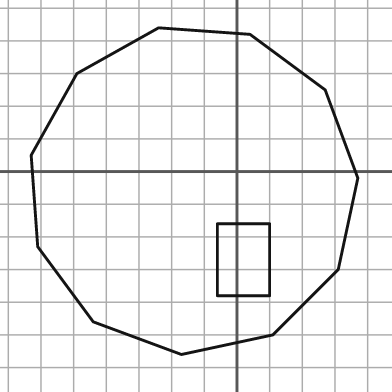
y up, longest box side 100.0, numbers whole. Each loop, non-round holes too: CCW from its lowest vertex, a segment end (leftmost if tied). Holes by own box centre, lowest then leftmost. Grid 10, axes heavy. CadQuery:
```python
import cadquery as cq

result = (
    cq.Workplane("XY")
    .moveTo(-17.0, -56.0)
    .lineTo(11.0, -50.0)
    .lineTo(31.0, -30.0)
    .lineTo(37.0, -2.0)
    .lineTo(27.0, 25.0)
    .lineTo(4.0, 42.0)
    .lineTo(-24.0, 44.0)
    .lineTo(-49.0, 30.0)
    .lineTo(-63.0, 5.0)
    .lineTo(-61.0, -23.0)
    .lineTo(-44.0, -46.0)
    .close()
    .moveTo(-6.0, -38.0)
    .lineTo(10.0, -38.0)
    .lineTo(10.0, -16.0)
    .lineTo(-6.0, -16.0)
    .close()
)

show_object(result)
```